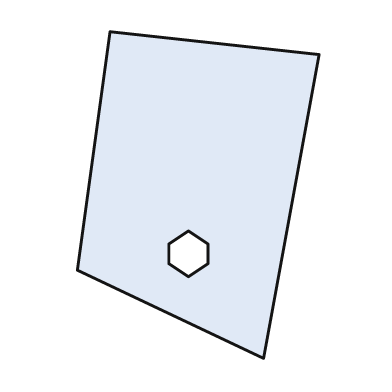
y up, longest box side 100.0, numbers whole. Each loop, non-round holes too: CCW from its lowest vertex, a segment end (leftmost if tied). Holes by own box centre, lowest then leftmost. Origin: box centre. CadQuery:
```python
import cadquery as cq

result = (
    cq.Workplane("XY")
    .moveTo(20.0, -50.0)
    .lineTo(37.0, 43.0)
    .lineTo(-27.0, 50.0)
    .lineTo(-37.0, -23.0)
    .close()
    .moveTo(-3.0, -25.0)
    .lineTo(3.0, -21.0)
    .lineTo(3.0, -15.0)
    .lineTo(-3.0, -11.0)
    .lineTo(-9.0, -15.0)
    .lineTo(-9.0, -21.0)
    .close()
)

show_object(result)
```